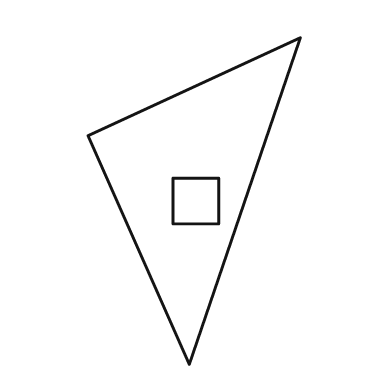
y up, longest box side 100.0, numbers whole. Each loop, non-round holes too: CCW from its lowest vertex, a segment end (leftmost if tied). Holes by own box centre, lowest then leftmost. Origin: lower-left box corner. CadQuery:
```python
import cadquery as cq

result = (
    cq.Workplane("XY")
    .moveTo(31.0, 0.0)
    .lineTo(65.0, 100.0)
    .lineTo(0.0, 70.0)
    .close()
    .moveTo(26.0, 43.0)
    .lineTo(40.0, 43.0)
    .lineTo(40.0, 57.0)
    .lineTo(26.0, 57.0)
    .close()
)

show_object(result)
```